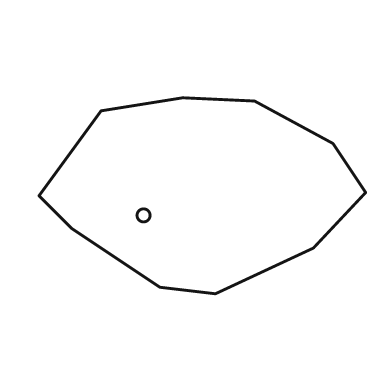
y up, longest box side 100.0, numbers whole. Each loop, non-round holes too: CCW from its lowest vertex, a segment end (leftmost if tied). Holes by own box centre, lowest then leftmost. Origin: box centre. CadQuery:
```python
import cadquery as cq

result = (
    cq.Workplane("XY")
    .moveTo(4.0, -30.0)
    .lineTo(34.0, -16.0)
    .lineTo(50.0, 1.0)
    .lineTo(40.0, 16.0)
    .lineTo(16.0, 29.0)
    .lineTo(-6.0, 30.0)
    .lineTo(-31.0, 26.0)
    .lineTo(-50.0, 0.0)
    .lineTo(-40.0, -10.0)
    .lineTo(-13.0, -28.0)
    .close()
    .moveTo(-18.0, -6.0)
    .circle(2.0)
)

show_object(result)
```